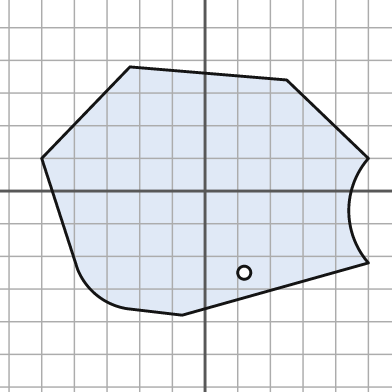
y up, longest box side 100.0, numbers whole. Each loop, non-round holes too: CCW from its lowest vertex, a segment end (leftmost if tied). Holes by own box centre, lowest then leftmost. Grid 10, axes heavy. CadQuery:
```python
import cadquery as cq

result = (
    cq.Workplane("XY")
    .moveTo(-7.0, -38.0)
    .lineTo(50.0, -22.0)
    .threePointArc((44.0, -6.0), (50.0, 10.0))
    .lineTo(25.0, 34.0)
    .lineTo(-23.0, 38.0)
    .lineTo(-50.0, 10.0)
    .lineTo(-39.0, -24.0)
    .threePointArc((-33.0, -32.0), (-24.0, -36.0))
    .close()
    .moveTo(12.0, -25.0)
    .circle(2.0)
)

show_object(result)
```